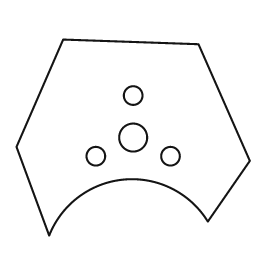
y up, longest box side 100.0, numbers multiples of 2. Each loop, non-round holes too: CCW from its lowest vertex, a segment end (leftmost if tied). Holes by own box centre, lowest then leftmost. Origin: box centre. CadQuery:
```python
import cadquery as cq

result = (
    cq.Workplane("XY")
    .moveTo(-36.0, -42.0)
    .threePointArc((-4.0, -18.0), (32.0, -36.0))
    .lineTo(50.0, -10.0)
    .lineTo(28.0, 40.0)
    .lineTo(-30.0, 42.0)
    .lineTo(-50.0, -4.0)
    .close()
    .moveTo(-16.0, -8.0)
    .circle(4.0)
    .moveTo(16.0, -8.0)
    .circle(4.0)
    .moveTo(0.0, 0.0)
    .circle(6.0)
    .moveTo(0.0, 18.0)
    .circle(4.0)
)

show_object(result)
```